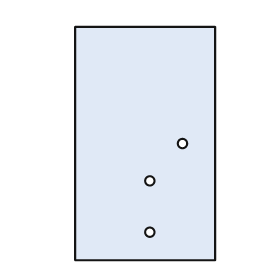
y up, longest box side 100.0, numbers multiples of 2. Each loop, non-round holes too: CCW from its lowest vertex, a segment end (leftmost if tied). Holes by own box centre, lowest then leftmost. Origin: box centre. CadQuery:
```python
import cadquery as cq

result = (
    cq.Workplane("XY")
    .moveTo(-30.0, -50.0)
    .lineTo(30.0, -50.0)
    .lineTo(30.0, 50.0)
    .lineTo(-30.0, 50.0)
    .close()
    .moveTo(2.0, -38.0)
    .circle(2.0)
    .moveTo(2.0, -16.0)
    .circle(2.0)
    .moveTo(16.0, 0.0)
    .circle(2.0)
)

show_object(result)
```